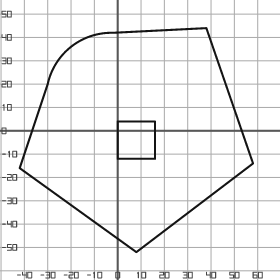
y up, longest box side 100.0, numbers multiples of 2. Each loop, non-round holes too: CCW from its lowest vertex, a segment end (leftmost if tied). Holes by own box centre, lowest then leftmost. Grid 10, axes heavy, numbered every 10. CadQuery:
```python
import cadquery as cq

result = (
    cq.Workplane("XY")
    .moveTo(8.0, -52.0)
    .lineTo(58.0, -14.0)
    .lineTo(38.0, 44.0)
    .lineTo(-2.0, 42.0)
    .threePointArc((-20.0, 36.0), (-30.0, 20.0))
    .lineTo(-42.0, -16.0)
    .close()
    .moveTo(0.0, -12.0)
    .lineTo(16.0, -12.0)
    .lineTo(16.0, 4.0)
    .lineTo(0.0, 4.0)
    .close()
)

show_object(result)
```